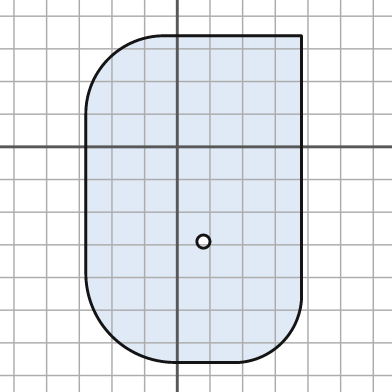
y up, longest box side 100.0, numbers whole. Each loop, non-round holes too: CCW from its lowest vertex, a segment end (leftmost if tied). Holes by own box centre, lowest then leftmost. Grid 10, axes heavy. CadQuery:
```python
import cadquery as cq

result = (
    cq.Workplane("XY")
    .moveTo(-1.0, -66.0)
    .lineTo(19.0, -66.0)
    .threePointArc((32.0, -60.0), (38.0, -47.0))
    .lineTo(38.0, 34.0)
    .lineTo(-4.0, 34.0)
    .threePointArc((-21.0, 27.0), (-28.0, 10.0))
    .lineTo(-28.0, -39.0)
    .threePointArc((-20.0, -58.0), (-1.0, -66.0))
    .close()
    .moveTo(8.0, -29.0)
    .circle(2.0)
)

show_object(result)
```